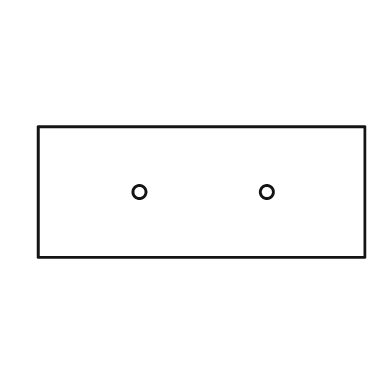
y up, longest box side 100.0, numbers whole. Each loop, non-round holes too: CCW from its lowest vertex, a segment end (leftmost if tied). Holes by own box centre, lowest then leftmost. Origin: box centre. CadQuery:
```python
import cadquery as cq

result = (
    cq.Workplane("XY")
    .moveTo(-50.0, -20.0)
    .lineTo(50.0, -20.0)
    .lineTo(50.0, 20.0)
    .lineTo(-50.0, 20.0)
    .close()
    .moveTo(-19.0, 0.0)
    .circle(2.0)
    .moveTo(20.0, 0.0)
    .circle(2.0)
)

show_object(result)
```